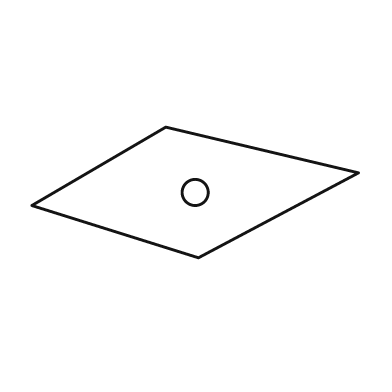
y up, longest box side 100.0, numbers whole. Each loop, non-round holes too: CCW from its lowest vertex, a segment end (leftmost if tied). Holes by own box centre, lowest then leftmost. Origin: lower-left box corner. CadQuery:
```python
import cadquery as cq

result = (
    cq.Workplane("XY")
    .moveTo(51.0, 0.0)
    .lineTo(100.0, 26.0)
    .lineTo(41.0, 40.0)
    .lineTo(0.0, 16.0)
    .close()
    .moveTo(50.0, 20.0)
    .circle(4.0)
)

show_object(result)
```